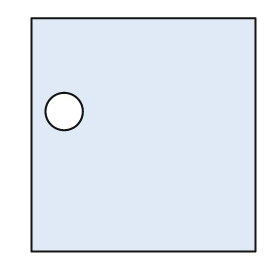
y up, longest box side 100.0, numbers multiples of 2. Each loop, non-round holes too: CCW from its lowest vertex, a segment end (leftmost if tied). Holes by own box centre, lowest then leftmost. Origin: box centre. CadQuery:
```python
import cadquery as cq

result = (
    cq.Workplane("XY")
    .moveTo(-48.0, -50.0)
    .lineTo(48.0, -50.0)
    .lineTo(48.0, 50.0)
    .lineTo(-48.0, 50.0)
    .close()
    .moveTo(-34.0, 10.0)
    .circle(8.0)
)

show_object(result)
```